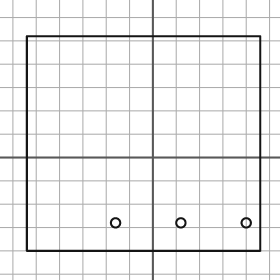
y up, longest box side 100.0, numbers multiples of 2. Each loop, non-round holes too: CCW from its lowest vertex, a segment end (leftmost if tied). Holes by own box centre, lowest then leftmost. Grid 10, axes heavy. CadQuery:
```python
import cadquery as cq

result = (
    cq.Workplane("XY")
    .moveTo(-54.0, -40.0)
    .lineTo(46.0, -40.0)
    .lineTo(46.0, 52.0)
    .lineTo(-54.0, 52.0)
    .close()
    .moveTo(-16.0, -28.0)
    .circle(2.0)
    .moveTo(12.0, -28.0)
    .circle(2.0)
    .moveTo(40.0, -28.0)
    .circle(2.0)
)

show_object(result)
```